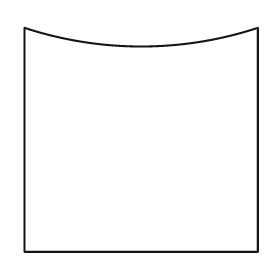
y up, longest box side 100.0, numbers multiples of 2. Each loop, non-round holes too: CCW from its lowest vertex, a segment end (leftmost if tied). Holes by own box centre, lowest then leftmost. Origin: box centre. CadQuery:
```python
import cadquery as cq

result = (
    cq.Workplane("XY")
    .moveTo(-50.0, -48.0)
    .lineTo(50.0, -48.0)
    .lineTo(50.0, 48.0)
    .threePointArc((0.0, 40.0), (-50.0, 48.0))
    .close()
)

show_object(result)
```